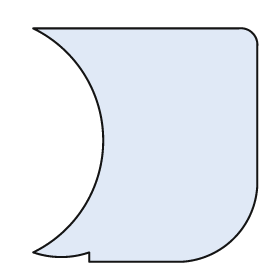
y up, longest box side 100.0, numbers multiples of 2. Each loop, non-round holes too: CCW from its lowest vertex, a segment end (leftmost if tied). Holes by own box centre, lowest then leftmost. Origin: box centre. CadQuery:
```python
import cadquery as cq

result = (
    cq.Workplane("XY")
    .moveTo(-24.0, -50.0)
    .lineTo(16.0, -50.0)
    .threePointArc((38.0, -40.0), (48.0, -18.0))
    .lineTo(48.0, 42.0)
    .threePointArc((46.0, 48.0), (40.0, 50.0))
    .lineTo(-48.0, 50.0)
    .threePointArc((-18.0, 2.0), (-48.0, -46.0))
    .threePointArc((-36.0, -48.0), (-24.0, -46.0))
    .close()
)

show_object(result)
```